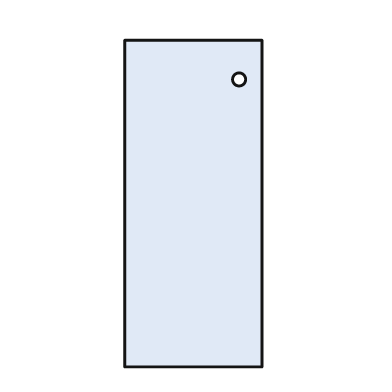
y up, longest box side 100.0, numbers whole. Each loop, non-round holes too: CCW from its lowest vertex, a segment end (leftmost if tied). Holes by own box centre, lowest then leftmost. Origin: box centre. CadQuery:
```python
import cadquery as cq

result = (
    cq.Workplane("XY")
    .moveTo(-21.0, -50.0)
    .lineTo(21.0, -50.0)
    .lineTo(21.0, 50.0)
    .lineTo(-21.0, 50.0)
    .close()
    .moveTo(14.0, 38.0)
    .circle(2.0)
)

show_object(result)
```